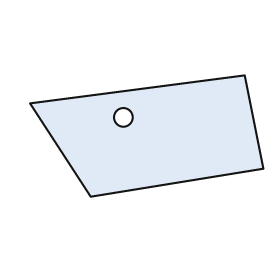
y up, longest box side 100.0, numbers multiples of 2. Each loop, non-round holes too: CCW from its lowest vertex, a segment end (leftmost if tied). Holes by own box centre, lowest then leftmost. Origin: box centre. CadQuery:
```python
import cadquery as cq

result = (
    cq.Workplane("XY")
    .moveTo(-24.0, -26.0)
    .lineTo(50.0, -14.0)
    .lineTo(42.0, 26.0)
    .lineTo(-50.0, 14.0)
    .close()
    .moveTo(-10.0, 8.0)
    .circle(4.0)
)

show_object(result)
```